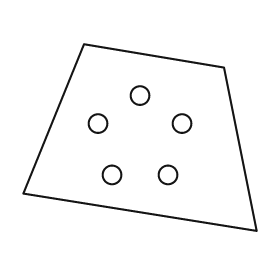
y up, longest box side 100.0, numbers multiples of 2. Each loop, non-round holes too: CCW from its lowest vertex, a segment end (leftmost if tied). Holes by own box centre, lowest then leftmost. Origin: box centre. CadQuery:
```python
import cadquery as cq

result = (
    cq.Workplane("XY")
    .moveTo(50.0, -40.0)
    .lineTo(36.0, 30.0)
    .lineTo(-24.0, 40.0)
    .lineTo(-50.0, -24.0)
    .close()
    .moveTo(-12.0, -16.0)
    .circle(4.0)
    .moveTo(12.0, -16.0)
    .circle(4.0)
    .moveTo(-18.0, 6.0)
    .circle(4.0)
    .moveTo(18.0, 6.0)
    .circle(4.0)
    .moveTo(0.0, 18.0)
    .circle(4.0)
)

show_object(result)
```